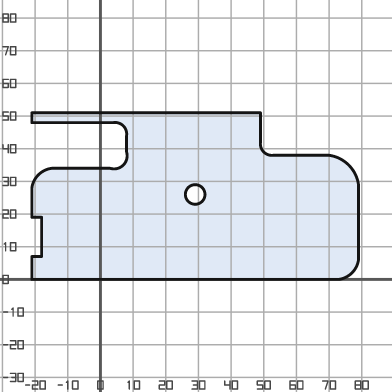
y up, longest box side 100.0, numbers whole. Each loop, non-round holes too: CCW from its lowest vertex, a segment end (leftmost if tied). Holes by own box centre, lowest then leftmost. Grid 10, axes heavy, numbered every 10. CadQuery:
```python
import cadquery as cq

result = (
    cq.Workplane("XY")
    .moveTo(-21.0, 0.0)
    .lineTo(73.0, 0.0)
    .threePointArc((77.0, 2.0), (79.0, 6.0))
    .lineTo(79.0, 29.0)
    .threePointArc((76.0, 35.0), (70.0, 38.0))
    .lineTo(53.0, 38.0)
    .threePointArc((50.0, 39.0), (49.0, 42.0))
    .lineTo(49.0, 51.0)
    .lineTo(-21.0, 51.0)
    .lineTo(-21.0, 48.0)
    .lineTo(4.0, 48.0)
    .threePointArc((7.0, 47.0), (8.0, 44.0))
    .lineTo(8.0, 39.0)
    .threePointArc((7.0, 35.0), (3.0, 34.0))
    .lineTo(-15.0, 34.0)
    .threePointArc((-19.0, 32.0), (-21.0, 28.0))
    .lineTo(-21.0, 19.0)
    .lineTo(-18.0, 19.0)
    .lineTo(-18.0, 7.0)
    .lineTo(-21.0, 7.0)
    .close()
    .moveTo(29.0, 26.0)
    .circle(3.0)
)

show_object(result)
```